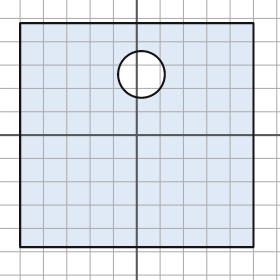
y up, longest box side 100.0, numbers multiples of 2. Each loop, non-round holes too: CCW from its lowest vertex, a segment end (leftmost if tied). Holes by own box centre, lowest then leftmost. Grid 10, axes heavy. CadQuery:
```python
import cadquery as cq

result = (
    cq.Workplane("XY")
    .moveTo(-50.0, -48.0)
    .lineTo(50.0, -48.0)
    .lineTo(50.0, 48.0)
    .lineTo(-50.0, 48.0)
    .close()
    .moveTo(2.0, 26.0)
    .circle(10.0)
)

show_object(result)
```